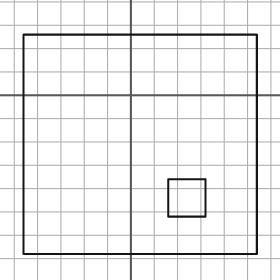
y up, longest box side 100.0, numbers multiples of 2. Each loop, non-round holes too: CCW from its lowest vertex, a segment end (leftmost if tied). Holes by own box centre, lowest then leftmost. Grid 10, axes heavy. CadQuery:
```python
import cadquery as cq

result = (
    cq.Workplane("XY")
    .moveTo(-46.0, -68.0)
    .lineTo(54.0, -68.0)
    .lineTo(54.0, 26.0)
    .lineTo(-46.0, 26.0)
    .close()
    .moveTo(16.0, -52.0)
    .lineTo(32.0, -52.0)
    .lineTo(32.0, -36.0)
    .lineTo(16.0, -36.0)
    .close()
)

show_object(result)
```